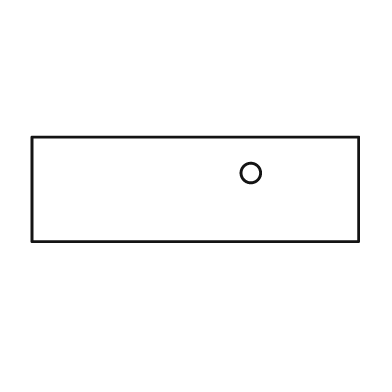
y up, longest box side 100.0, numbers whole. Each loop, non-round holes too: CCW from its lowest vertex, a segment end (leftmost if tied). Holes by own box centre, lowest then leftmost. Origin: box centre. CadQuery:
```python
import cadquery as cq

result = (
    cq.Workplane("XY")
    .moveTo(-50.0, -16.0)
    .lineTo(50.0, -16.0)
    .lineTo(50.0, 16.0)
    .lineTo(-50.0, 16.0)
    .close()
    .moveTo(17.0, 5.0)
    .circle(3.0)
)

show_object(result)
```